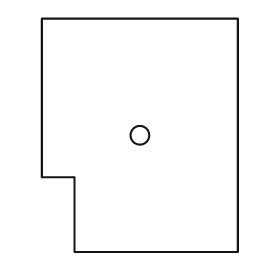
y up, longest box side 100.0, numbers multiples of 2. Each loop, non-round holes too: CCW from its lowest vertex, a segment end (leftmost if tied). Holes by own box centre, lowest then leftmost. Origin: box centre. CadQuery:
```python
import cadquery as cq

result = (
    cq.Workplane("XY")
    .moveTo(-28.0, -50.0)
    .lineTo(42.0, -50.0)
    .lineTo(42.0, 50.0)
    .lineTo(-42.0, 50.0)
    .lineTo(-42.0, -18.0)
    .lineTo(-28.0, -18.0)
    .close()
    .moveTo(0.0, 0.0)
    .circle(4.0)
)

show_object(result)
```